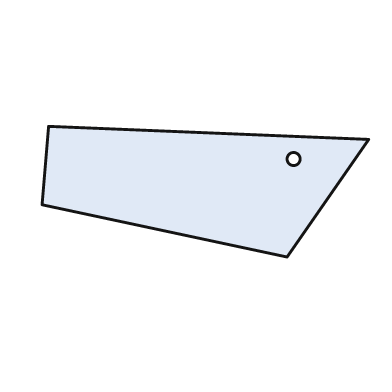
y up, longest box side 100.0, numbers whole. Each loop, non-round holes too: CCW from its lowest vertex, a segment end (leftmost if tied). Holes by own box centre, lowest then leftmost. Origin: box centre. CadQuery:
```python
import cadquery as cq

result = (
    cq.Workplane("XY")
    .moveTo(25.0, -20.0)
    .lineTo(50.0, 16.0)
    .lineTo(-48.0, 20.0)
    .lineTo(-50.0, -4.0)
    .close()
    .moveTo(27.0, 10.0)
    .circle(2.0)
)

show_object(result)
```